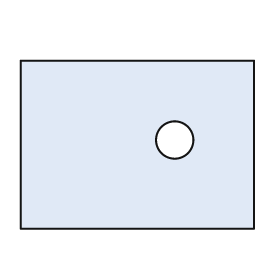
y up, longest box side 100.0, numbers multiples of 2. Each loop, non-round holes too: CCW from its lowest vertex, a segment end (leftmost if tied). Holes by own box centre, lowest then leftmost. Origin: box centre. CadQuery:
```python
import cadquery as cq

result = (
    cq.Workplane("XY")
    .moveTo(-50.0, -36.0)
    .lineTo(50.0, -36.0)
    .lineTo(50.0, 36.0)
    .lineTo(-50.0, 36.0)
    .close()
    .moveTo(16.0, 2.0)
    .circle(8.0)
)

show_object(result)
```